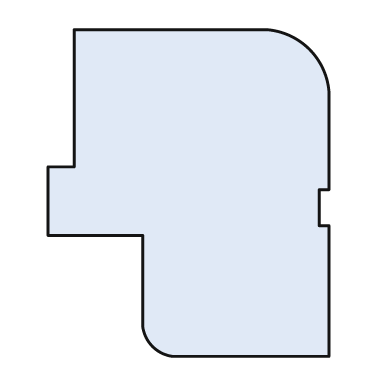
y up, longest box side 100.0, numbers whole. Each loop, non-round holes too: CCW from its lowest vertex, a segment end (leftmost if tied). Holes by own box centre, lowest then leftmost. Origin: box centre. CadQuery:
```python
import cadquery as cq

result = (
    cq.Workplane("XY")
    .moveTo(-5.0, -50.0)
    .lineTo(43.0, -50.0)
    .lineTo(43.0, -10.0)
    .lineTo(40.0, -10.0)
    .lineTo(40.0, 1.0)
    .lineTo(43.0, 1.0)
    .lineTo(43.0, 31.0)
    .threePointArc((37.0, 44.0), (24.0, 50.0))
    .lineTo(-35.0, 50.0)
    .lineTo(-35.0, 8.0)
    .lineTo(-43.0, 8.0)
    .lineTo(-43.0, -13.0)
    .lineTo(-14.0, -13.0)
    .lineTo(-14.0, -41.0)
    .threePointArc((-11.0, -47.0), (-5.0, -50.0))
    .close()
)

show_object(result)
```